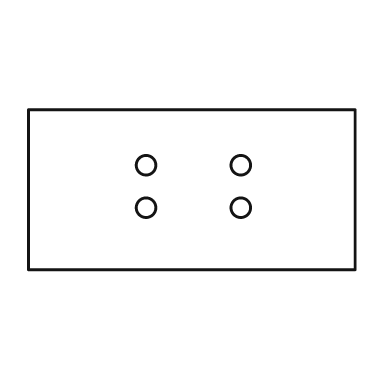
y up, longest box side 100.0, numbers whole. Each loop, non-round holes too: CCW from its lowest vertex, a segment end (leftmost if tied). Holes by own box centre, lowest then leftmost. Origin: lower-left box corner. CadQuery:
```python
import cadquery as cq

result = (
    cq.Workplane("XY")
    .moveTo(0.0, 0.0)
    .lineTo(100.0, 0.0)
    .lineTo(100.0, 49.0)
    .lineTo(0.0, 49.0)
    .close()
    .moveTo(36.0, 19.0)
    .circle(3.0)
    .moveTo(65.0, 19.0)
    .circle(3.0)
    .moveTo(36.0, 32.0)
    .circle(3.0)
    .moveTo(65.0, 32.0)
    .circle(3.0)
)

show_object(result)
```